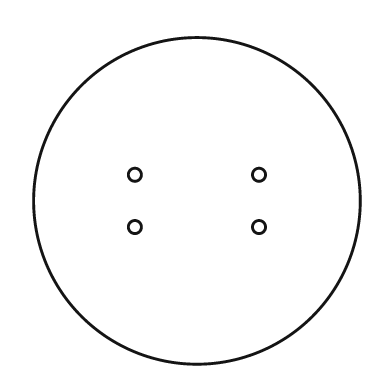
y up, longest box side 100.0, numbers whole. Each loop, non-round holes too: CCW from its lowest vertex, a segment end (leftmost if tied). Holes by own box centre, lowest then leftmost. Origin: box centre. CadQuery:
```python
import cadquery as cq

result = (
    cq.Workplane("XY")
    .moveTo(0.0, 0.0)
    .circle(50.0)
    .moveTo(-19.0, -8.0)
    .circle(2.0)
    .moveTo(19.0, -8.0)
    .circle(2.0)
    .moveTo(-19.0, 8.0)
    .circle(2.0)
    .moveTo(19.0, 8.0)
    .circle(2.0)
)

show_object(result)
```